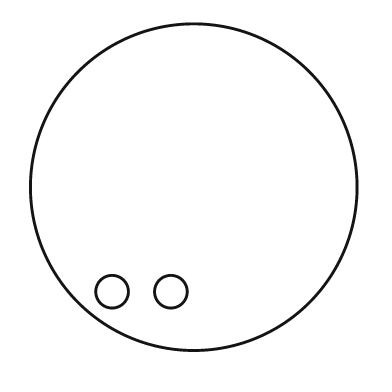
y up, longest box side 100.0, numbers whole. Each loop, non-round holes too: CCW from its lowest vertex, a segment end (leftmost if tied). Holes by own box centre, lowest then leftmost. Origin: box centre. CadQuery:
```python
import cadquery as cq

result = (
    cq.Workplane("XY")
    .moveTo(0.0, 0.0)
    .circle(50.0)
    .moveTo(-25.0, -32.0)
    .circle(5.0)
    .moveTo(-7.0, -32.0)
    .circle(5.0)
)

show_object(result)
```